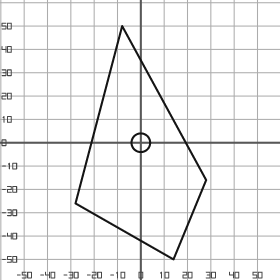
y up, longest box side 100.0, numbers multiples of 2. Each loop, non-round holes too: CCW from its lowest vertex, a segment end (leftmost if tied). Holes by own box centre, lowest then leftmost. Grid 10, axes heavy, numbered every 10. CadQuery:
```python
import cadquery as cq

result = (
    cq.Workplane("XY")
    .moveTo(14.0, -50.0)
    .lineTo(28.0, -16.0)
    .lineTo(-8.0, 50.0)
    .lineTo(-28.0, -26.0)
    .close()
    .moveTo(0.0, 0.0)
    .circle(4.0)
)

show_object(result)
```